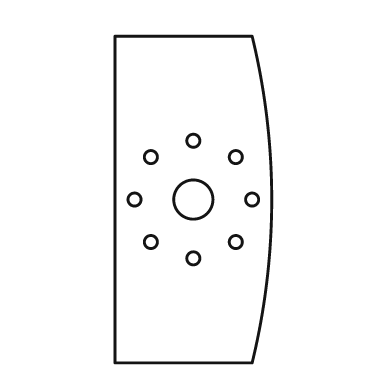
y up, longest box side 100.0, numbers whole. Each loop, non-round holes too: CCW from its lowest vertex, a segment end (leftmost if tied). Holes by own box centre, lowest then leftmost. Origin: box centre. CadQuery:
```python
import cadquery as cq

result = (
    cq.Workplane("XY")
    .moveTo(-24.0, -50.0)
    .lineTo(18.0, -50.0)
    .threePointArc((24.0, 0.0), (18.0, 50.0))
    .lineTo(-24.0, 50.0)
    .close()
    .moveTo(0.0, -18.0)
    .circle(2.0)
    .moveTo(-13.0, -13.0)
    .circle(2.0)
    .moveTo(13.0, -13.0)
    .circle(2.0)
    .moveTo(-18.0, 0.0)
    .circle(2.0)
    .moveTo(0.0, 0.0)
    .circle(6.0)
    .moveTo(18.0, 0.0)
    .circle(2.0)
    .moveTo(-13.0, 13.0)
    .circle(2.0)
    .moveTo(13.0, 13.0)
    .circle(2.0)
    .moveTo(0.0, 18.0)
    .circle(2.0)
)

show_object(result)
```